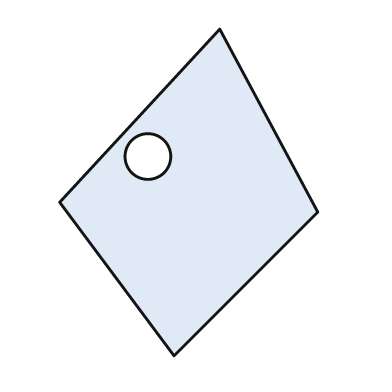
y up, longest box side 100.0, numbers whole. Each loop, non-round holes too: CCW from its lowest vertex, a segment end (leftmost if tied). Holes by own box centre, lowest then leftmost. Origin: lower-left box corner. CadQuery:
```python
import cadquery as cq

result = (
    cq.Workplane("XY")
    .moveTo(35.0, 0.0)
    .lineTo(79.0, 44.0)
    .lineTo(49.0, 100.0)
    .lineTo(0.0, 47.0)
    .close()
    .moveTo(27.0, 61.0)
    .circle(7.0)
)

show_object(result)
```